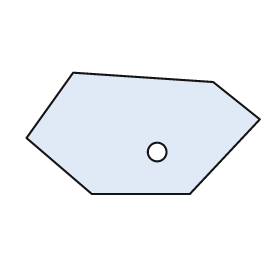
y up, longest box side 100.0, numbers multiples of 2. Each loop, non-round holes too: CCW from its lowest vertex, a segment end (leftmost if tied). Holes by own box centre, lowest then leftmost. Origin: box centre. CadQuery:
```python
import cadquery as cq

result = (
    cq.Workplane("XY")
    .moveTo(-22.0, -26.0)
    .lineTo(20.0, -26.0)
    .lineTo(50.0, 6.0)
    .lineTo(30.0, 22.0)
    .lineTo(-30.0, 26.0)
    .lineTo(-50.0, -2.0)
    .close()
    .moveTo(6.0, -8.0)
    .circle(4.0)
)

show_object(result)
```